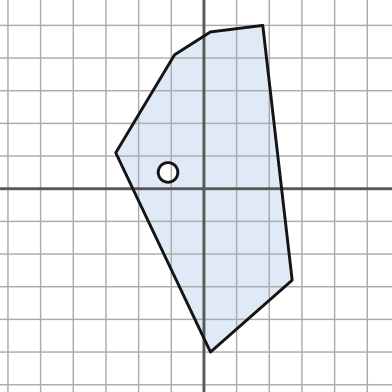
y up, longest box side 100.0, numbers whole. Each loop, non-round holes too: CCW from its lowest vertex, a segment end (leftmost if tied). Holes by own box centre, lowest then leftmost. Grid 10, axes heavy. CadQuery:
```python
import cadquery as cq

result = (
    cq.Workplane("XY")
    .moveTo(2.0, -50.0)
    .lineTo(27.0, -28.0)
    .lineTo(18.0, 50.0)
    .lineTo(2.0, 48.0)
    .lineTo(-9.0, 41.0)
    .lineTo(-27.0, 11.0)
    .close()
    .moveTo(-11.0, 5.0)
    .circle(3.0)
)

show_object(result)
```